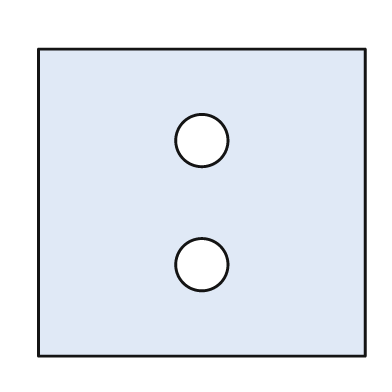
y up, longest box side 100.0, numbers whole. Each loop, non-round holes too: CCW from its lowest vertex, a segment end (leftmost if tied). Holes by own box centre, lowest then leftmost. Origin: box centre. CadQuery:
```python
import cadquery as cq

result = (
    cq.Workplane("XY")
    .moveTo(-50.0, -47.0)
    .lineTo(50.0, -47.0)
    .lineTo(50.0, 47.0)
    .lineTo(-50.0, 47.0)
    .close()
    .moveTo(0.0, -19.0)
    .circle(8.0)
    .moveTo(0.0, 19.0)
    .circle(8.0)
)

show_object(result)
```